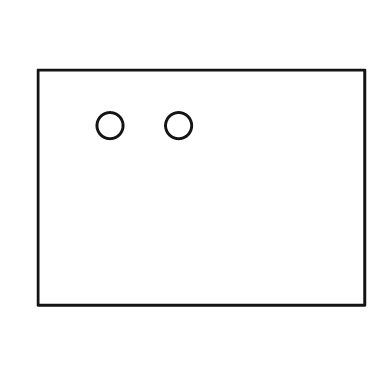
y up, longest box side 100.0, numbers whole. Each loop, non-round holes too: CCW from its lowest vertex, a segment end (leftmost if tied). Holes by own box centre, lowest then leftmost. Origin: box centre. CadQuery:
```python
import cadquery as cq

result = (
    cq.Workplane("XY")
    .moveTo(-50.0, -36.0)
    .lineTo(50.0, -36.0)
    .lineTo(50.0, 36.0)
    .lineTo(-50.0, 36.0)
    .close()
    .moveTo(-28.0, 19.0)
    .circle(4.0)
    .moveTo(-7.0, 19.0)
    .circle(4.0)
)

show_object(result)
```